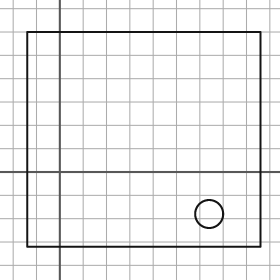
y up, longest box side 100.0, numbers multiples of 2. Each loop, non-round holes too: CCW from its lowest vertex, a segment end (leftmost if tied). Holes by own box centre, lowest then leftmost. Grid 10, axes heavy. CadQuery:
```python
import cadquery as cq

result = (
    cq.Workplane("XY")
    .moveTo(-14.0, -32.0)
    .lineTo(86.0, -32.0)
    .lineTo(86.0, 60.0)
    .lineTo(-14.0, 60.0)
    .close()
    .moveTo(64.0, -18.0)
    .circle(6.0)
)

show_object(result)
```